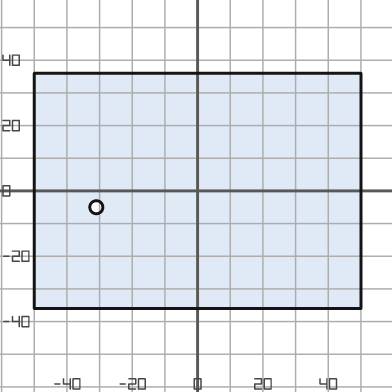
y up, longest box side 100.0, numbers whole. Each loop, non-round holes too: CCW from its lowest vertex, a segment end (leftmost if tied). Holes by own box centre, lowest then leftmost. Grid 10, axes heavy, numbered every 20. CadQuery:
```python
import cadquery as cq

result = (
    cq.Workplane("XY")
    .moveTo(-50.0, -36.0)
    .lineTo(50.0, -36.0)
    .lineTo(50.0, 36.0)
    .lineTo(-50.0, 36.0)
    .close()
    .moveTo(-31.0, -5.0)
    .circle(2.0)
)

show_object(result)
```